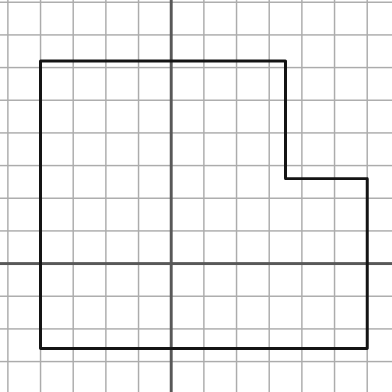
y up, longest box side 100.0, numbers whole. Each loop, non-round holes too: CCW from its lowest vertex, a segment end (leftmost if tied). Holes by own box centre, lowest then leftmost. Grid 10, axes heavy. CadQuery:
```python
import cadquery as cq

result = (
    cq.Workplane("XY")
    .moveTo(-40.0, -26.0)
    .lineTo(60.0, -26.0)
    .lineTo(60.0, 26.0)
    .lineTo(35.0, 26.0)
    .lineTo(35.0, 62.0)
    .lineTo(-40.0, 62.0)
    .close()
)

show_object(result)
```